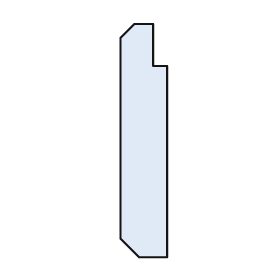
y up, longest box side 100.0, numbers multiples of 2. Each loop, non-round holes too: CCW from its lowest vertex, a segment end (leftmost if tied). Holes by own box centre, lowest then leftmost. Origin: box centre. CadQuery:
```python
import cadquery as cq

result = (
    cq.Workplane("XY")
    .moveTo(-2.0, -50.0)
    .lineTo(10.0, -50.0)
    .lineTo(10.0, 32.0)
    .lineTo(4.0, 32.0)
    .lineTo(4.0, 50.0)
    .lineTo(-4.0, 50.0)
    .lineTo(-10.0, 44.0)
    .lineTo(-10.0, -42.0)
    .close()
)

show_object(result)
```